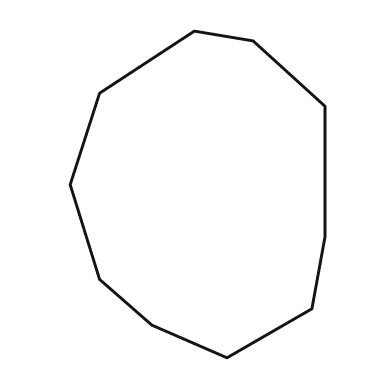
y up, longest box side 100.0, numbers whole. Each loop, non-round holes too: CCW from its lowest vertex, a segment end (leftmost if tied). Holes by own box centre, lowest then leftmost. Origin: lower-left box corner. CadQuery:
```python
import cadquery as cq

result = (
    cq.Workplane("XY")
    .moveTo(48.0, 0.0)
    .lineTo(74.0, 15.0)
    .lineTo(78.0, 37.0)
    .lineTo(78.0, 77.0)
    .lineTo(56.0, 97.0)
    .lineTo(38.0, 100.0)
    .lineTo(9.0, 81.0)
    .lineTo(0.0, 53.0)
    .lineTo(9.0, 24.0)
    .lineTo(25.0, 10.0)
    .close()
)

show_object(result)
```